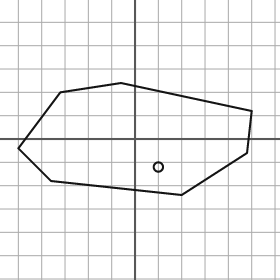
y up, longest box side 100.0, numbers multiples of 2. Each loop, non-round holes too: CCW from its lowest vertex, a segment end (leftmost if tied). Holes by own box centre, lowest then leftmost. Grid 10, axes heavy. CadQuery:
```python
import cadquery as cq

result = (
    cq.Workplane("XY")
    .moveTo(20.0, -24.0)
    .lineTo(48.0, -6.0)
    .lineTo(50.0, 12.0)
    .lineTo(-6.0, 24.0)
    .lineTo(-32.0, 20.0)
    .lineTo(-50.0, -4.0)
    .lineTo(-36.0, -18.0)
    .close()
    .moveTo(10.0, -12.0)
    .circle(2.0)
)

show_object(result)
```